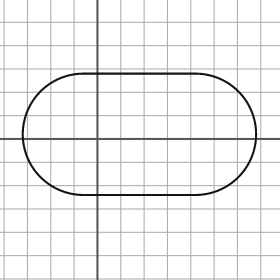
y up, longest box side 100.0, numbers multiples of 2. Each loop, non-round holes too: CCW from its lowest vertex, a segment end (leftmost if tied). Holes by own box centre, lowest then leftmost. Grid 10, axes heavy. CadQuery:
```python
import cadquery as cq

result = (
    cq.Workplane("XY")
    .moveTo(-6.0, -24.0)
    .lineTo(42.0, -24.0)
    .threePointArc((68.0, 2.0), (42.0, 28.0))
    .lineTo(-6.0, 28.0)
    .threePointArc((-32.0, 2.0), (-6.0, -24.0))
    .close()
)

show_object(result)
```